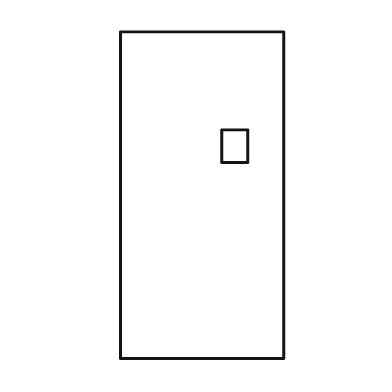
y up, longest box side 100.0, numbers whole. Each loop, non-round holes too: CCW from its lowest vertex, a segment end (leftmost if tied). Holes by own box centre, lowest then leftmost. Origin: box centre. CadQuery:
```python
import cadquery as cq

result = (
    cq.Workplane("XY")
    .moveTo(-25.0, -50.0)
    .lineTo(25.0, -50.0)
    .lineTo(25.0, 50.0)
    .lineTo(-25.0, 50.0)
    .close()
    .moveTo(6.0, 10.0)
    .lineTo(14.0, 10.0)
    .lineTo(14.0, 20.0)
    .lineTo(6.0, 20.0)
    .close()
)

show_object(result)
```